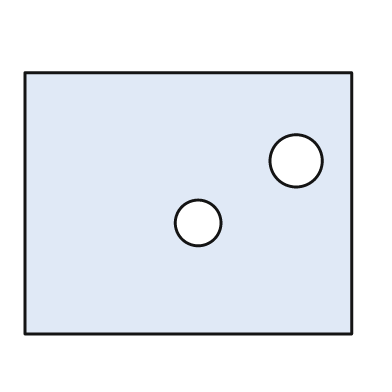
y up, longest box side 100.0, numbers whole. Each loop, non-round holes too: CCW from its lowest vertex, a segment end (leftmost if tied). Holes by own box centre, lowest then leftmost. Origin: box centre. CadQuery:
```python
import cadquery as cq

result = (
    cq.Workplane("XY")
    .moveTo(-50.0, -40.0)
    .lineTo(50.0, -40.0)
    .lineTo(50.0, 40.0)
    .lineTo(-50.0, 40.0)
    .close()
    .moveTo(3.0, -6.0)
    .circle(7.0)
    .moveTo(33.0, 13.0)
    .circle(8.0)
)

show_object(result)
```